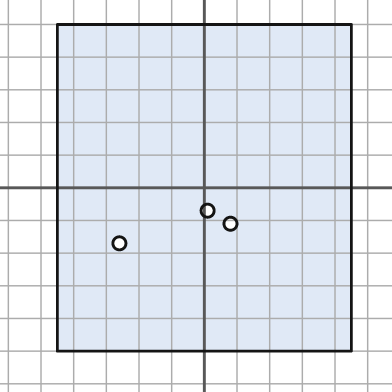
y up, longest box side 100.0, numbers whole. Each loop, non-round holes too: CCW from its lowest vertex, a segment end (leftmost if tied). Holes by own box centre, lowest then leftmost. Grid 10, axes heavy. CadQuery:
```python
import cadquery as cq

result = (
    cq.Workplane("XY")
    .moveTo(-45.0, -50.0)
    .lineTo(45.0, -50.0)
    .lineTo(45.0, 50.0)
    .lineTo(-45.0, 50.0)
    .close()
    .moveTo(-26.0, -17.0)
    .circle(2.0)
    .moveTo(8.0, -11.0)
    .circle(2.0)
    .moveTo(1.0, -7.0)
    .circle(2.0)
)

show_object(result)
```